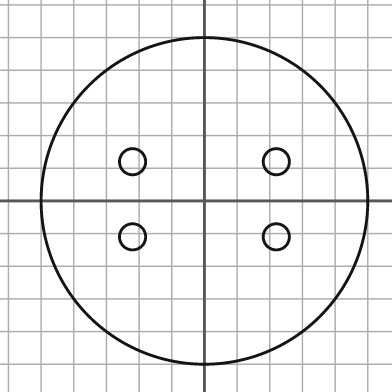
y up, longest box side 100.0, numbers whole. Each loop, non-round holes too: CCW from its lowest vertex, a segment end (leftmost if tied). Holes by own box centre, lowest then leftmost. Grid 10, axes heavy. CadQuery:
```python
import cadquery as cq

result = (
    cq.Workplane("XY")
    .moveTo(0.0, 0.0)
    .circle(50.0)
    .moveTo(-22.0, -11.0)
    .circle(4.0)
    .moveTo(22.0, -11.0)
    .circle(4.0)
    .moveTo(-22.0, 12.0)
    .circle(4.0)
    .moveTo(22.0, 12.0)
    .circle(4.0)
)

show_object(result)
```